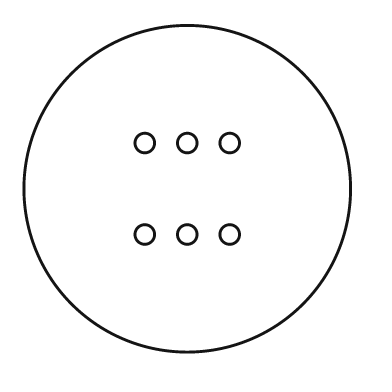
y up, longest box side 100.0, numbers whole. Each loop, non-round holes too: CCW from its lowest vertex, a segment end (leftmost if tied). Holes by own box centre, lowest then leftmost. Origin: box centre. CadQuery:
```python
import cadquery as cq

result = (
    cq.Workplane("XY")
    .moveTo(0.0, 0.0)
    .circle(50.0)
    .moveTo(-13.0, -14.0)
    .circle(3.0)
    .moveTo(0.0, -14.0)
    .circle(3.0)
    .moveTo(13.0, -14.0)
    .circle(3.0)
    .moveTo(-13.0, 14.0)
    .circle(3.0)
    .moveTo(0.0, 14.0)
    .circle(3.0)
    .moveTo(13.0, 14.0)
    .circle(3.0)
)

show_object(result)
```